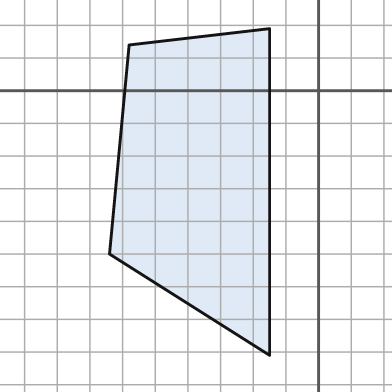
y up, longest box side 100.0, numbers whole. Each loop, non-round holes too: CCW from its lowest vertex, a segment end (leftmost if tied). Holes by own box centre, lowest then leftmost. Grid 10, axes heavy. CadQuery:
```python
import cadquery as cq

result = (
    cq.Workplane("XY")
    .moveTo(-15.0, -81.0)
    .lineTo(-15.0, 19.0)
    .lineTo(-58.0, 14.0)
    .lineTo(-64.0, -50.0)
    .close()
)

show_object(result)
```